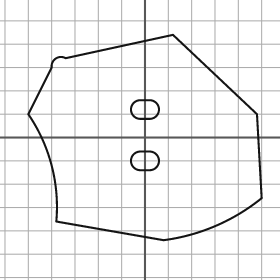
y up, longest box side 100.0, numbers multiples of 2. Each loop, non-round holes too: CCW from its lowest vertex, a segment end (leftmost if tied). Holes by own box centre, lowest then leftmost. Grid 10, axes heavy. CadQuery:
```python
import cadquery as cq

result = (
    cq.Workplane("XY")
    .moveTo(8.0, -44.0)
    .threePointArc((30.0, -38.0), (50.0, -26.0))
    .lineTo(48.0, 10.0)
    .lineTo(12.0, 44.0)
    .lineTo(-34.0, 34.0)
    .threePointArc((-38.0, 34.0), (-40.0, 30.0))
    .lineTo(-50.0, 10.0)
    .threePointArc((-40.0, -12.0), (-38.0, -36.0))
    .close()
    .moveTo(-2.0, -14.0)
    .lineTo(2.0, -14.0)
    .threePointArc((6.0, -10.0), (2.0, -6.0))
    .lineTo(-2.0, -6.0)
    .threePointArc((-6.0, -10.0), (-2.0, -14.0))
    .close()
    .moveTo(-2.0, 8.0)
    .lineTo(2.0, 8.0)
    .threePointArc((6.0, 12.0), (2.0, 16.0))
    .lineTo(-2.0, 16.0)
    .threePointArc((-6.0, 12.0), (-2.0, 8.0))
    .close()
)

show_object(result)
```